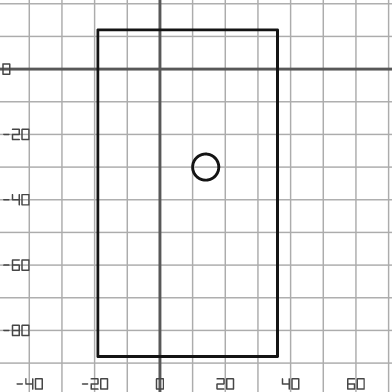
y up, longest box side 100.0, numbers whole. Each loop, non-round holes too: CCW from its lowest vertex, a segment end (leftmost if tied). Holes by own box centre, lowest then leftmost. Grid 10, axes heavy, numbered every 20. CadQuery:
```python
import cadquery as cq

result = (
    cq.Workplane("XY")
    .moveTo(-19.0, -88.0)
    .lineTo(36.0, -88.0)
    .lineTo(36.0, 12.0)
    .lineTo(-19.0, 12.0)
    .close()
    .moveTo(14.0, -30.0)
    .circle(4.0)
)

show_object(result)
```